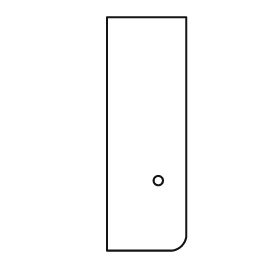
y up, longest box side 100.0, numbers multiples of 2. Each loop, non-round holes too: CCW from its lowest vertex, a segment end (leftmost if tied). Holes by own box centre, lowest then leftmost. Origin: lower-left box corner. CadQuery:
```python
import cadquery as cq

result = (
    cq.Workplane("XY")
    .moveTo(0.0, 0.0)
    .lineTo(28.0, 0.0)
    .threePointArc((32.0, 2.0), (34.0, 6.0))
    .lineTo(34.0, 100.0)
    .lineTo(0.0, 100.0)
    .close()
    .moveTo(22.0, 30.0)
    .circle(2.0)
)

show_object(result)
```